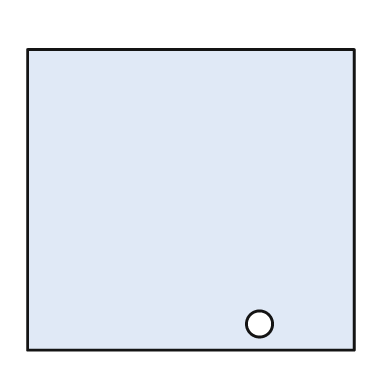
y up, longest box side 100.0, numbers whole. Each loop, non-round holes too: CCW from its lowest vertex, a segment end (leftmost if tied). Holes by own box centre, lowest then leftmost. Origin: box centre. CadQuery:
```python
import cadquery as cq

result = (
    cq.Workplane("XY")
    .moveTo(-50.0, -46.0)
    .lineTo(50.0, -46.0)
    .lineTo(50.0, 46.0)
    .lineTo(-50.0, 46.0)
    .close()
    .moveTo(21.0, -38.0)
    .circle(4.0)
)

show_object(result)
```